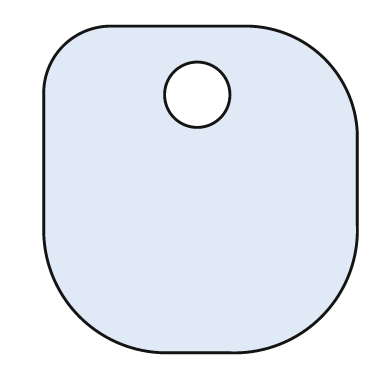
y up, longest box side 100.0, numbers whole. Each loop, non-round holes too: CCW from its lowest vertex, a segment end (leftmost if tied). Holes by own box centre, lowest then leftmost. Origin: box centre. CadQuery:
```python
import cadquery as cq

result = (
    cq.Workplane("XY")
    .moveTo(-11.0, -50.0)
    .lineTo(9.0, -50.0)
    .threePointArc((37.0, -39.0), (48.0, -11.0))
    .lineTo(48.0, 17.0)
    .threePointArc((38.0, 40.0), (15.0, 50.0))
    .lineTo(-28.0, 50.0)
    .threePointArc((-42.0, 44.0), (-48.0, 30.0))
    .lineTo(-48.0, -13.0)
    .threePointArc((-37.0, -39.0), (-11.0, -50.0))
    .close()
    .moveTo(-1.0, 29.0)
    .circle(10.0)
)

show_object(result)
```